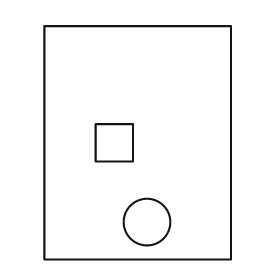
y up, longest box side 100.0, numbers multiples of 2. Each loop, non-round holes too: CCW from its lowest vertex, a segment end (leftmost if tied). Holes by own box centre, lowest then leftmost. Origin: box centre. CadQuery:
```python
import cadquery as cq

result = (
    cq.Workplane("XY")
    .moveTo(-40.0, -50.0)
    .lineTo(40.0, -50.0)
    .lineTo(40.0, 50.0)
    .lineTo(-40.0, 50.0)
    .close()
    .moveTo(4.0, -34.0)
    .circle(10.0)
    .moveTo(-18.0, -8.0)
    .lineTo(-2.0, -8.0)
    .lineTo(-2.0, 8.0)
    .lineTo(-18.0, 8.0)
    .close()
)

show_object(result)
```